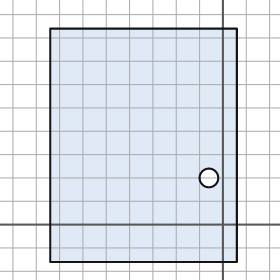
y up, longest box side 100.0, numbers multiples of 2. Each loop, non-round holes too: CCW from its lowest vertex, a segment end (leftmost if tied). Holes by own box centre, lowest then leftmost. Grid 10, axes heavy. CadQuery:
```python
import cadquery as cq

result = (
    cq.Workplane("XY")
    .moveTo(-74.0, -16.0)
    .lineTo(6.0, -16.0)
    .lineTo(6.0, 84.0)
    .lineTo(-74.0, 84.0)
    .close()
    .moveTo(-6.0, 20.0)
    .circle(4.0)
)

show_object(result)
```